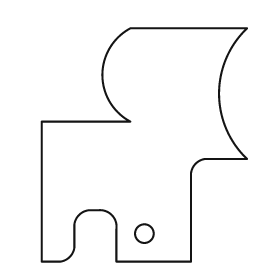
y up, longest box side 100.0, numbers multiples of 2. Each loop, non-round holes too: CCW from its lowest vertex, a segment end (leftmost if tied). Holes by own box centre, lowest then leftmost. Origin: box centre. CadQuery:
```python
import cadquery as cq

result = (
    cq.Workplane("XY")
    .moveTo(-44.0, -50.0)
    .lineTo(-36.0, -50.0)
    .threePointArc((-32.0, -48.0), (-30.0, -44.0))
    .lineTo(-30.0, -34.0)
    .threePointArc((-28.0, -30.0), (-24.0, -28.0))
    .lineTo(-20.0, -28.0)
    .threePointArc((-14.0, -30.0), (-12.0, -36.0))
    .lineTo(-12.0, -50.0)
    .lineTo(20.0, -50.0)
    .lineTo(20.0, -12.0)
    .threePointArc((22.0, -8.0), (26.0, -6.0))
    .lineTo(44.0, -6.0)
    .threePointArc((32.0, 22.0), (44.0, 50.0))
    .lineTo(-6.0, 50.0)
    .threePointArc((-18.0, 30.0), (-6.0, 10.0))
    .lineTo(-44.0, 10.0)
    .close()
    .moveTo(0.0, -38.0)
    .circle(4.0)
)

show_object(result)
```